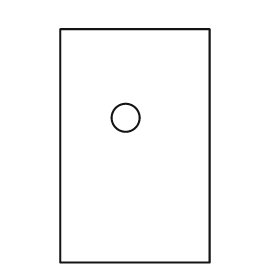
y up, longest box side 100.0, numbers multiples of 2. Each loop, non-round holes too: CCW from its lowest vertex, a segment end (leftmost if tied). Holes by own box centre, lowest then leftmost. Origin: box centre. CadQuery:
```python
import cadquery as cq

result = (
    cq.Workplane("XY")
    .moveTo(-32.0, -50.0)
    .lineTo(32.0, -50.0)
    .lineTo(32.0, 50.0)
    .lineTo(-32.0, 50.0)
    .close()
    .moveTo(-4.0, 12.0)
    .circle(6.0)
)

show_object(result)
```